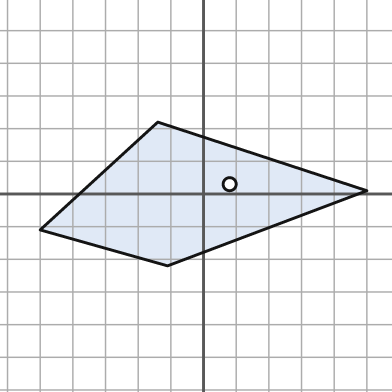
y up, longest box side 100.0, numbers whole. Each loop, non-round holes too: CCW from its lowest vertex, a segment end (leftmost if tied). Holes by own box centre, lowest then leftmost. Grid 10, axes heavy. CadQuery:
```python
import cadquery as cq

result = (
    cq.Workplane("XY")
    .moveTo(-11.0, -22.0)
    .lineTo(50.0, 1.0)
    .lineTo(-14.0, 22.0)
    .lineTo(-50.0, -11.0)
    .close()
    .moveTo(8.0, 3.0)
    .circle(2.0)
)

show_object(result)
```